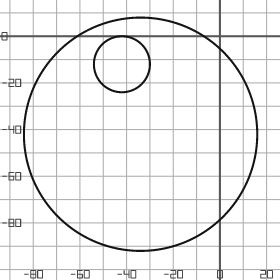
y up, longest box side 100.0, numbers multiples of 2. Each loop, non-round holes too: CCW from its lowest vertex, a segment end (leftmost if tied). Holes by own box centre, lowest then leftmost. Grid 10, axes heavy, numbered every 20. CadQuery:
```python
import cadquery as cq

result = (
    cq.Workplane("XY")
    .moveTo(-34.0, -42.0)
    .circle(50.0)
    .moveTo(-42.0, -12.0)
    .circle(12.0)
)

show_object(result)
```